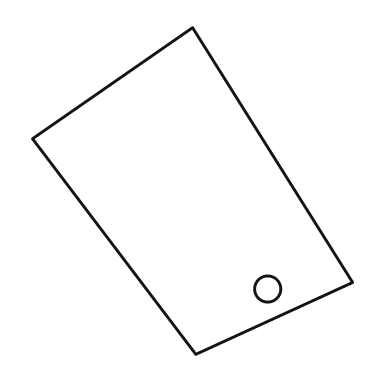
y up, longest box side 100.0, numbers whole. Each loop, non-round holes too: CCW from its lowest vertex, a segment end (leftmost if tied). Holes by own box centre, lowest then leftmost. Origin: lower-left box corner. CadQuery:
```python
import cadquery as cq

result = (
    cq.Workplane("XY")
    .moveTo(50.0, 0.0)
    .lineTo(98.0, 22.0)
    .lineTo(49.0, 100.0)
    .lineTo(0.0, 66.0)
    .close()
    .moveTo(72.0, 20.0)
    .circle(4.0)
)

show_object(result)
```